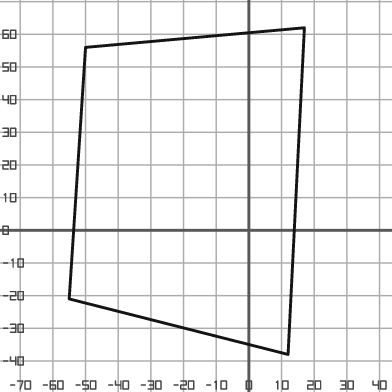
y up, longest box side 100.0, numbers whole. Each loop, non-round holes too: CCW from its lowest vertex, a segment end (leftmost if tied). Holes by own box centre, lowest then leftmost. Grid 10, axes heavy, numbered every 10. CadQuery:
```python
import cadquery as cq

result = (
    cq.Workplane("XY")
    .moveTo(12.0, -38.0)
    .lineTo(17.0, 62.0)
    .lineTo(-50.0, 56.0)
    .lineTo(-55.0, -21.0)
    .close()
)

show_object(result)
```